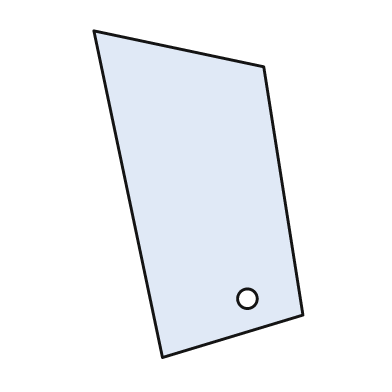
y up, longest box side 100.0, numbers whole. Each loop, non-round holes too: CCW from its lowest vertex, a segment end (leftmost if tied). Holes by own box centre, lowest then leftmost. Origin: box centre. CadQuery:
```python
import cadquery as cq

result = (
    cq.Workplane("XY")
    .moveTo(-11.0, -50.0)
    .lineTo(32.0, -37.0)
    .lineTo(20.0, 39.0)
    .lineTo(-32.0, 50.0)
    .close()
    .moveTo(15.0, -32.0)
    .circle(3.0)
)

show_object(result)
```